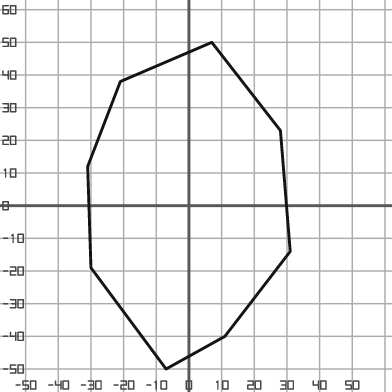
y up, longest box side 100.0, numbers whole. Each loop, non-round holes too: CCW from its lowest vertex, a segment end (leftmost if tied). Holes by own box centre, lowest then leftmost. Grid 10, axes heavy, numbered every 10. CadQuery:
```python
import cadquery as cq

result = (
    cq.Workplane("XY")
    .moveTo(-7.0, -50.0)
    .lineTo(11.0, -40.0)
    .lineTo(31.0, -14.0)
    .lineTo(28.0, 23.0)
    .lineTo(7.0, 50.0)
    .lineTo(-21.0, 38.0)
    .lineTo(-31.0, 12.0)
    .lineTo(-30.0, -19.0)
    .close()
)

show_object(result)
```